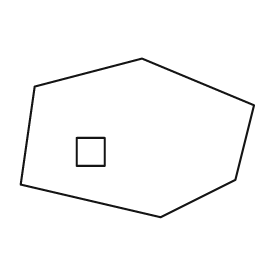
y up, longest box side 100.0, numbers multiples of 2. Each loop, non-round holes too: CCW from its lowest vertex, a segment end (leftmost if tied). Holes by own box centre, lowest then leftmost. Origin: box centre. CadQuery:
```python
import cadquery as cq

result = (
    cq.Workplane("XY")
    .moveTo(10.0, -34.0)
    .lineTo(42.0, -18.0)
    .lineTo(50.0, 14.0)
    .lineTo(2.0, 34.0)
    .lineTo(-44.0, 22.0)
    .lineTo(-50.0, -20.0)
    .close()
    .moveTo(-26.0, -12.0)
    .lineTo(-14.0, -12.0)
    .lineTo(-14.0, 0.0)
    .lineTo(-26.0, 0.0)
    .close()
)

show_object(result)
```